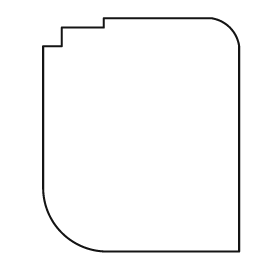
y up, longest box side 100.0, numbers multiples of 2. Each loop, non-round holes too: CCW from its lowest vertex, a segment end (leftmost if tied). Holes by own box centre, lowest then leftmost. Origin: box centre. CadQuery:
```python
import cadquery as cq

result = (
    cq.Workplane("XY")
    .moveTo(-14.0, -50.0)
    .lineTo(42.0, -50.0)
    .lineTo(42.0, 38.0)
    .threePointArc((38.0, 46.0), (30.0, 50.0))
    .lineTo(-16.0, 50.0)
    .lineTo(-16.0, 46.0)
    .lineTo(-34.0, 46.0)
    .lineTo(-34.0, 38.0)
    .lineTo(-42.0, 38.0)
    .lineTo(-42.0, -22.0)
    .threePointArc((-34.0, -42.0), (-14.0, -50.0))
    .close()
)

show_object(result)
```